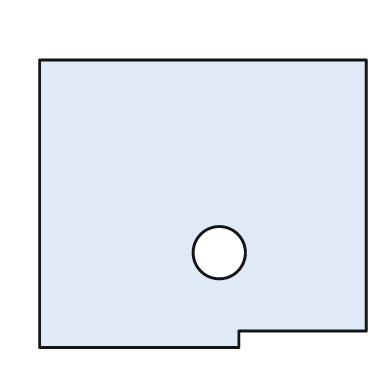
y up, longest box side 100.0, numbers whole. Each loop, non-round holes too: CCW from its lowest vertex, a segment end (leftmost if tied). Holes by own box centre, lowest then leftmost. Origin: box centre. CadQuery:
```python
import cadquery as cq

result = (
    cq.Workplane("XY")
    .moveTo(-50.0, -44.0)
    .lineTo(11.0, -44.0)
    .lineTo(11.0, -39.0)
    .lineTo(50.0, -39.0)
    .lineTo(50.0, 44.0)
    .lineTo(-50.0, 44.0)
    .close()
    .moveTo(5.0, -15.0)
    .circle(8.0)
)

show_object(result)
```